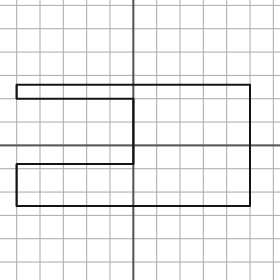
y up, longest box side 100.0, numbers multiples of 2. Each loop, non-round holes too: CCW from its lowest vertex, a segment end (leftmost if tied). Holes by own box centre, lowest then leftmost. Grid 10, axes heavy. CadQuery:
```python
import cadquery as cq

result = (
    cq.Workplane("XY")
    .moveTo(-50.0, -26.0)
    .lineTo(50.0, -26.0)
    .lineTo(50.0, 26.0)
    .lineTo(-50.0, 26.0)
    .lineTo(-50.0, 20.0)
    .lineTo(0.0, 20.0)
    .lineTo(0.0, -8.0)
    .lineTo(-50.0, -8.0)
    .close()
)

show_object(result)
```